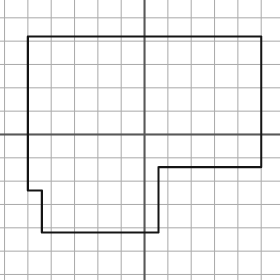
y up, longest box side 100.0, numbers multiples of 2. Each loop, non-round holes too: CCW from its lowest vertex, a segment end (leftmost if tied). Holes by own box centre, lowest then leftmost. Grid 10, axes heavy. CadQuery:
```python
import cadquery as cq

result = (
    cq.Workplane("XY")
    .moveTo(-44.0, -42.0)
    .lineTo(6.0, -42.0)
    .lineTo(6.0, -14.0)
    .lineTo(50.0, -14.0)
    .lineTo(50.0, 42.0)
    .lineTo(-50.0, 42.0)
    .lineTo(-50.0, -24.0)
    .lineTo(-44.0, -24.0)
    .close()
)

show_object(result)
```